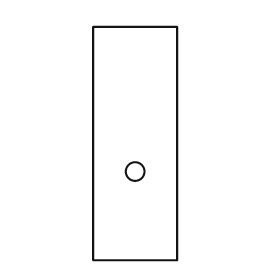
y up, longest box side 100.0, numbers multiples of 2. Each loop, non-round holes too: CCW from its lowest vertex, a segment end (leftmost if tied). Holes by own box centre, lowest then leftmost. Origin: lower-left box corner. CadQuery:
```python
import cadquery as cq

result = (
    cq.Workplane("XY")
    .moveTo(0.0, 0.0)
    .lineTo(36.0, 0.0)
    .lineTo(36.0, 100.0)
    .lineTo(0.0, 100.0)
    .close()
    .moveTo(18.0, 38.0)
    .circle(4.0)
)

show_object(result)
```